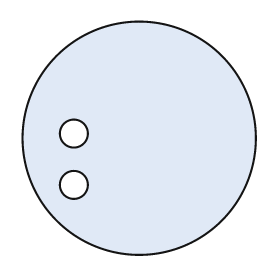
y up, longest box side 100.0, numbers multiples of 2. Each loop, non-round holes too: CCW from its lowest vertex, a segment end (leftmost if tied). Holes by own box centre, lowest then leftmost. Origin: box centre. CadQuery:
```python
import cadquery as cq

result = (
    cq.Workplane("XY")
    .moveTo(0.0, 0.0)
    .circle(50.0)
    .moveTo(-28.0, -20.0)
    .circle(6.0)
    .moveTo(-28.0, 2.0)
    .circle(6.0)
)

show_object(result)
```